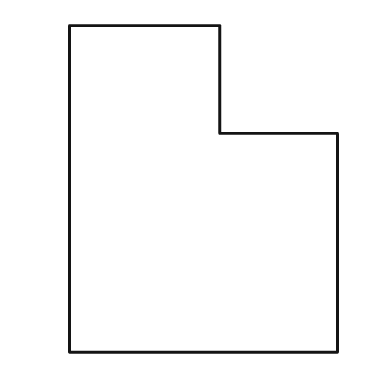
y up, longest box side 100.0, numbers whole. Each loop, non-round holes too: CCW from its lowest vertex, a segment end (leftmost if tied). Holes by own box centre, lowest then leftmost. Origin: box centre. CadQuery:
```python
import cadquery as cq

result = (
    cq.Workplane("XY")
    .moveTo(-41.0, -50.0)
    .lineTo(41.0, -50.0)
    .lineTo(41.0, 17.0)
    .lineTo(5.0, 17.0)
    .lineTo(5.0, 50.0)
    .lineTo(-41.0, 50.0)
    .close()
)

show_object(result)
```